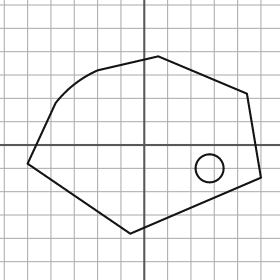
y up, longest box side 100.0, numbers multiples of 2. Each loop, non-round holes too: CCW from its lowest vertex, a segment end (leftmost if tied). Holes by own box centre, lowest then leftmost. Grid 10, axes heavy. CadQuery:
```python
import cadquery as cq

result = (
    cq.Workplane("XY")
    .moveTo(-6.0, -38.0)
    .lineTo(50.0, -14.0)
    .lineTo(44.0, 22.0)
    .lineTo(6.0, 38.0)
    .lineTo(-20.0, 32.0)
    .threePointArc((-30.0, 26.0), (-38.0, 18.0))
    .lineTo(-50.0, -8.0)
    .close()
    .moveTo(28.0, -10.0)
    .circle(6.0)
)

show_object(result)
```